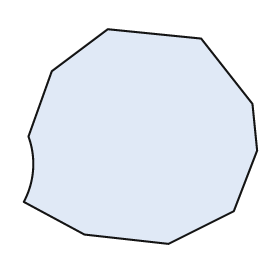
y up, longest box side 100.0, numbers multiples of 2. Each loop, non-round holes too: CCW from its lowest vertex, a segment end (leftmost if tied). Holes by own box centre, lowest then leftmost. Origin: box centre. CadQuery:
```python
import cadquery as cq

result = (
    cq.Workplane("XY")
    .moveTo(12.0, -46.0)
    .lineTo(40.0, -32.0)
    .lineTo(50.0, -6.0)
    .lineTo(48.0, 14.0)
    .lineTo(26.0, 42.0)
    .lineTo(-14.0, 46.0)
    .lineTo(-38.0, 28.0)
    .lineTo(-48.0, 0.0)
    .threePointArc((-46.0, -14.0), (-50.0, -28.0))
    .lineTo(-24.0, -42.0)
    .close()
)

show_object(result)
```